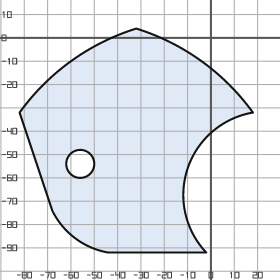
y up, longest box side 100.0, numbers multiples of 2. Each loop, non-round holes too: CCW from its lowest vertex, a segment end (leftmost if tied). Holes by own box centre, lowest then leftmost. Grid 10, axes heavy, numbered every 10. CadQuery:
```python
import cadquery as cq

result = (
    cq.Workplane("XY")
    .moveTo(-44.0, -92.0)
    .lineTo(-2.0, -92.0)
    .threePointArc((-10.0, -56.0), (18.0, -32.0))
    .threePointArc((-4.0, -10.0), (-32.0, 4.0))
    .threePointArc((-60.0, -10.0), (-82.0, -32.0))
    .lineTo(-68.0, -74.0)
    .threePointArc((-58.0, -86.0), (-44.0, -92.0))
    .close()
    .moveTo(-56.0, -54.0)
    .circle(6.0)
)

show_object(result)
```